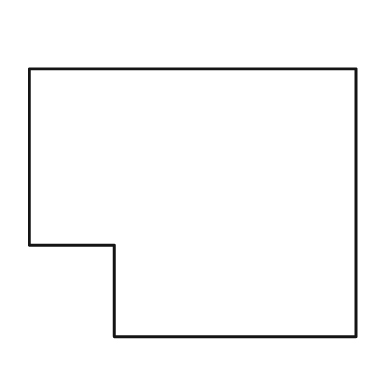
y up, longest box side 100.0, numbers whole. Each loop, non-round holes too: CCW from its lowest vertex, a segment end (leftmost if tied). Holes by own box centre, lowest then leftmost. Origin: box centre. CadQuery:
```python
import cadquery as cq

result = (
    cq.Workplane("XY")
    .moveTo(-24.0, -41.0)
    .lineTo(50.0, -41.0)
    .lineTo(50.0, 41.0)
    .lineTo(-50.0, 41.0)
    .lineTo(-50.0, -13.0)
    .lineTo(-24.0, -13.0)
    .close()
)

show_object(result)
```